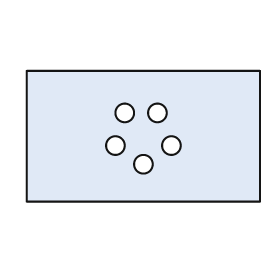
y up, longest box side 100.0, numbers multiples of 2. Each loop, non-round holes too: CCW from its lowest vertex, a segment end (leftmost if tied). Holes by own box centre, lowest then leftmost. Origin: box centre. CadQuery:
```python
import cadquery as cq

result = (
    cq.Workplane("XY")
    .moveTo(-50.0, -28.0)
    .lineTo(50.0, -28.0)
    .lineTo(50.0, 28.0)
    .lineTo(-50.0, 28.0)
    .close()
    .moveTo(0.0, -12.0)
    .circle(4.0)
    .moveTo(-12.0, -4.0)
    .circle(4.0)
    .moveTo(12.0, -4.0)
    .circle(4.0)
    .moveTo(-8.0, 10.0)
    .circle(4.0)
    .moveTo(6.0, 10.0)
    .circle(4.0)
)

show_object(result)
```